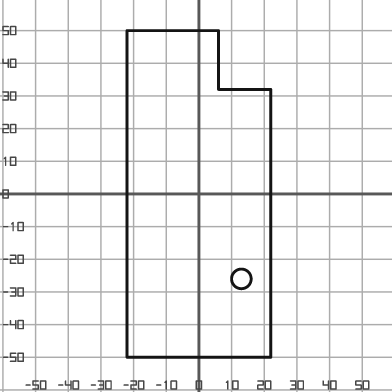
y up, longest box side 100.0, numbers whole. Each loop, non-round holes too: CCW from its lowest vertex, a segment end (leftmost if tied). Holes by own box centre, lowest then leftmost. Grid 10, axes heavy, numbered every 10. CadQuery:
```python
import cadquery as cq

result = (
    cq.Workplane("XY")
    .moveTo(-22.0, -50.0)
    .lineTo(22.0, -50.0)
    .lineTo(22.0, 32.0)
    .lineTo(6.0, 32.0)
    .lineTo(6.0, 50.0)
    .lineTo(-22.0, 50.0)
    .close()
    .moveTo(13.0, -26.0)
    .circle(3.0)
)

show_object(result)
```